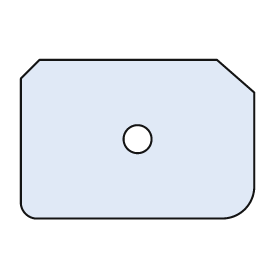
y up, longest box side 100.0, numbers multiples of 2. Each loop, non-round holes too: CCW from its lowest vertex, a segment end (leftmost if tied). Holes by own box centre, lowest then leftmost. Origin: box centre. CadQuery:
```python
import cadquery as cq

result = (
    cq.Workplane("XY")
    .moveTo(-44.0, -34.0)
    .lineTo(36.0, -34.0)
    .threePointArc((46.0, -30.0), (50.0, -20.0))
    .lineTo(50.0, 20.0)
    .lineTo(34.0, 34.0)
    .lineTo(-42.0, 34.0)
    .lineTo(-50.0, 26.0)
    .lineTo(-50.0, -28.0)
    .threePointArc((-48.0, -32.0), (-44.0, -34.0))
    .close()
    .moveTo(0.0, 0.0)
    .circle(6.0)
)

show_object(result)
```